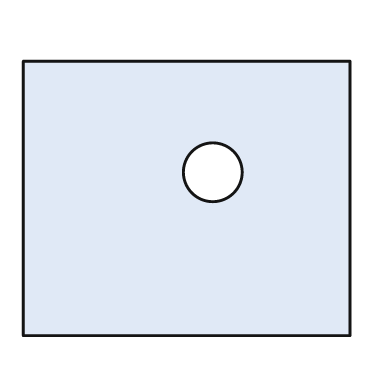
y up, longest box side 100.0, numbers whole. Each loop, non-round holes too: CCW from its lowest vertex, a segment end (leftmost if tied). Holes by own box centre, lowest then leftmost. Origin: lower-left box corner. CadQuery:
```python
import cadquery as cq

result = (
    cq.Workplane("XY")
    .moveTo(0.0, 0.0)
    .lineTo(100.0, 0.0)
    .lineTo(100.0, 84.0)
    .lineTo(0.0, 84.0)
    .close()
    .moveTo(58.0, 50.0)
    .circle(9.0)
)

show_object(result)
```